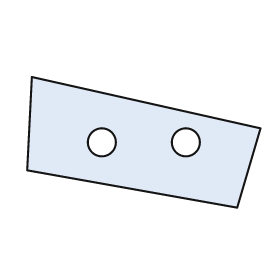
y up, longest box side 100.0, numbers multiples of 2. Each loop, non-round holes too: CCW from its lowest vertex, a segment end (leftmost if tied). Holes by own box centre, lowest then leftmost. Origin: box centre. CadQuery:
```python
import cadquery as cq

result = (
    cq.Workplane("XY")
    .moveTo(40.0, -28.0)
    .lineTo(50.0, 6.0)
    .lineTo(-48.0, 28.0)
    .lineTo(-50.0, -12.0)
    .close()
    .moveTo(-18.0, 0.0)
    .circle(6.0)
    .moveTo(18.0, 0.0)
    .circle(6.0)
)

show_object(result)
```